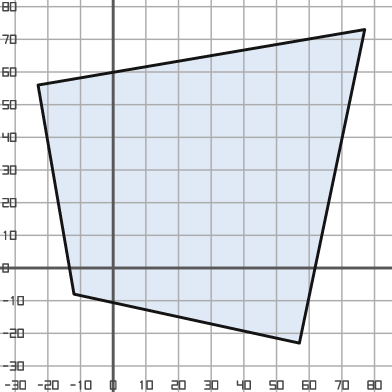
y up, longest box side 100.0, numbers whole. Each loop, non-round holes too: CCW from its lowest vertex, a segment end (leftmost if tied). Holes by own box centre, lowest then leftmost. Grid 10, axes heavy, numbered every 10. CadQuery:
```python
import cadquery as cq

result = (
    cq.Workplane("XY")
    .moveTo(57.0, -23.0)
    .lineTo(77.0, 73.0)
    .lineTo(-23.0, 56.0)
    .lineTo(-12.0, -8.0)
    .close()
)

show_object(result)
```